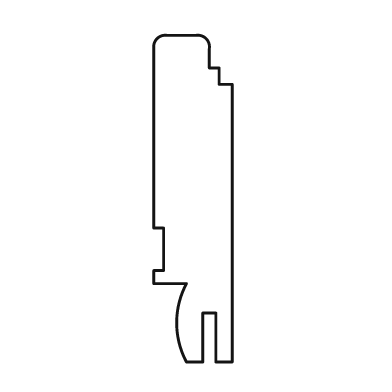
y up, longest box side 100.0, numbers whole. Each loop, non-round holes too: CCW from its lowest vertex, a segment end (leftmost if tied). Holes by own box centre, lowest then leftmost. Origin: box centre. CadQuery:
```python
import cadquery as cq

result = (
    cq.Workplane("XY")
    .moveTo(-2.0, -50.0)
    .lineTo(3.0, -50.0)
    .lineTo(3.0, -35.0)
    .lineTo(7.0, -35.0)
    .lineTo(7.0, -50.0)
    .lineTo(12.0, -50.0)
    .lineTo(12.0, 35.0)
    .lineTo(8.0, 35.0)
    .lineTo(8.0, 40.0)
    .lineTo(5.0, 40.0)
    .lineTo(5.0, 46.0)
    .threePointArc((4.0, 49.0), (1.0, 50.0))
    .lineTo(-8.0, 50.0)
    .threePointArc((-11.0, 49.0), (-12.0, 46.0))
    .lineTo(-12.0, -9.0)
    .lineTo(-9.0, -9.0)
    .lineTo(-9.0, -22.0)
    .lineTo(-12.0, -22.0)
    .lineTo(-12.0, -26.0)
    .lineTo(-2.0, -26.0)
    .threePointArc((-5.0, -38.0), (-2.0, -50.0))
    .close()
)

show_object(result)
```